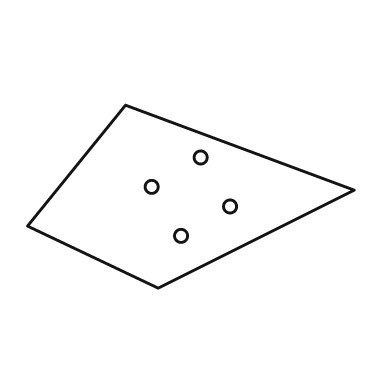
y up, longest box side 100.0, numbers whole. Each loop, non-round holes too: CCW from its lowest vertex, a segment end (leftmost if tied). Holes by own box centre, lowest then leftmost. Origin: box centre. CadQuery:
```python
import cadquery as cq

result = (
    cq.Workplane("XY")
    .moveTo(-10.0, -28.0)
    .lineTo(50.0, 2.0)
    .lineTo(-20.0, 28.0)
    .lineTo(-50.0, -9.0)
    .close()
    .moveTo(-3.0, -12.0)
    .circle(2.0)
    .moveTo(12.0, -3.0)
    .circle(2.0)
    .moveTo(-12.0, 3.0)
    .circle(2.0)
    .moveTo(3.0, 12.0)
    .circle(2.0)
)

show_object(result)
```